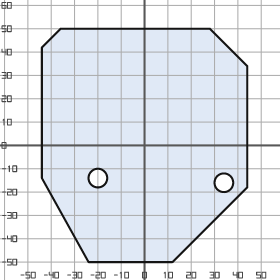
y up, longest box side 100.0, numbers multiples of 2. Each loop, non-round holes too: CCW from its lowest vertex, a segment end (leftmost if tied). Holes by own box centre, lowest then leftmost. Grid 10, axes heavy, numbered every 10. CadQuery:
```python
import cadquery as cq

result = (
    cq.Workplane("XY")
    .moveTo(-24.0, -50.0)
    .lineTo(12.0, -50.0)
    .lineTo(44.0, -18.0)
    .lineTo(44.0, 34.0)
    .lineTo(28.0, 50.0)
    .lineTo(-36.0, 50.0)
    .lineTo(-44.0, 42.0)
    .lineTo(-44.0, -14.0)
    .close()
    .moveTo(34.0, -16.0)
    .circle(4.0)
    .moveTo(-20.0, -14.0)
    .circle(4.0)
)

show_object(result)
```